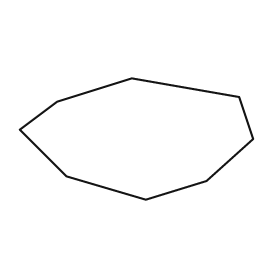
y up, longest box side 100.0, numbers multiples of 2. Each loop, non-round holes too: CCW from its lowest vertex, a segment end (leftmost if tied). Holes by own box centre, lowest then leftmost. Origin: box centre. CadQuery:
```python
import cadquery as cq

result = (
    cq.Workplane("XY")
    .moveTo(4.0, -26.0)
    .lineTo(30.0, -18.0)
    .lineTo(50.0, 0.0)
    .lineTo(44.0, 18.0)
    .lineTo(-2.0, 26.0)
    .lineTo(-34.0, 16.0)
    .lineTo(-50.0, 4.0)
    .lineTo(-30.0, -16.0)
    .close()
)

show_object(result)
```